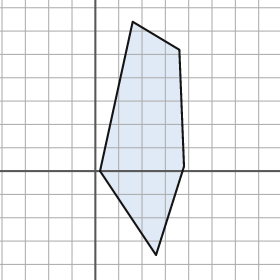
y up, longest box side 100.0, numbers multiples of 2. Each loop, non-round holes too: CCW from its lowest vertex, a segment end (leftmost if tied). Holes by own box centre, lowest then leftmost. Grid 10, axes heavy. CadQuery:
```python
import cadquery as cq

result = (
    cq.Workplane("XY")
    .moveTo(26.0, -36.0)
    .lineTo(38.0, 2.0)
    .lineTo(36.0, 52.0)
    .lineTo(16.0, 64.0)
    .lineTo(2.0, 0.0)
    .close()
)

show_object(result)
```